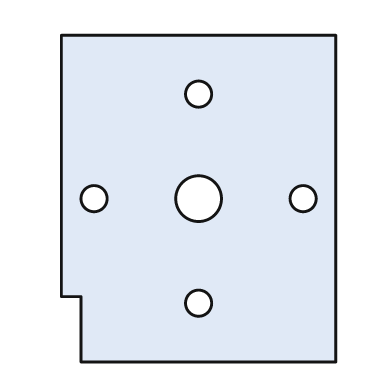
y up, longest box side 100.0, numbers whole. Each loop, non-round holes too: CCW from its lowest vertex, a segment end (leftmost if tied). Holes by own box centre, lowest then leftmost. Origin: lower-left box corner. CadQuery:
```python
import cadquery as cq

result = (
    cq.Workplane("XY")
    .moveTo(6.0, 0.0)
    .lineTo(84.0, 0.0)
    .lineTo(84.0, 100.0)
    .lineTo(0.0, 100.0)
    .lineTo(0.0, 20.0)
    .lineTo(6.0, 20.0)
    .close()
    .moveTo(42.0, 18.0)
    .circle(4.0)
    .moveTo(10.0, 50.0)
    .circle(4.0)
    .moveTo(42.0, 50.0)
    .circle(7.0)
    .moveTo(74.0, 50.0)
    .circle(4.0)
    .moveTo(42.0, 82.0)
    .circle(4.0)
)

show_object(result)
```